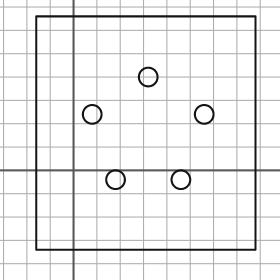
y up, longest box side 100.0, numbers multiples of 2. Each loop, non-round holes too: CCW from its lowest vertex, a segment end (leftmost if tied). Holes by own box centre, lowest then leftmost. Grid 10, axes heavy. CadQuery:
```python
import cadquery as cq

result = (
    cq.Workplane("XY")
    .moveTo(-16.0, -34.0)
    .lineTo(78.0, -34.0)
    .lineTo(78.0, 66.0)
    .lineTo(-16.0, 66.0)
    .close()
    .moveTo(18.0, -4.0)
    .circle(4.0)
    .moveTo(46.0, -4.0)
    .circle(4.0)
    .moveTo(8.0, 24.0)
    .circle(4.0)
    .moveTo(56.0, 24.0)
    .circle(4.0)
    .moveTo(32.0, 40.0)
    .circle(4.0)
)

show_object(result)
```